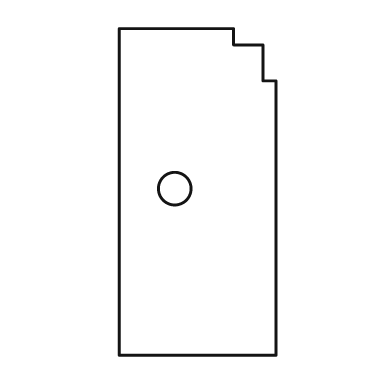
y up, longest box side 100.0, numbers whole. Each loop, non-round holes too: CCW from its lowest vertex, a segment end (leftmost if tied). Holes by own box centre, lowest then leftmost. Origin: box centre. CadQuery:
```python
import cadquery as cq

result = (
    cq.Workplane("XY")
    .moveTo(-24.0, -50.0)
    .lineTo(24.0, -50.0)
    .lineTo(24.0, 34.0)
    .lineTo(20.0, 34.0)
    .lineTo(20.0, 45.0)
    .lineTo(11.0, 45.0)
    .lineTo(11.0, 50.0)
    .lineTo(-24.0, 50.0)
    .close()
    .moveTo(-7.0, 1.0)
    .circle(5.0)
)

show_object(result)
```